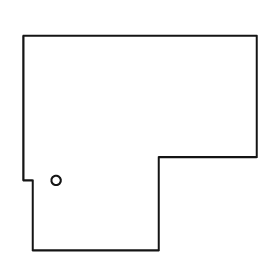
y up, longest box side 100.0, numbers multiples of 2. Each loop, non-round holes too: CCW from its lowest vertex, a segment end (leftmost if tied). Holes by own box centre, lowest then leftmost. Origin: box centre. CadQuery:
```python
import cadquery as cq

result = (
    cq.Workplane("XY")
    .moveTo(-46.0, -46.0)
    .lineTo(8.0, -46.0)
    .lineTo(8.0, -6.0)
    .lineTo(50.0, -6.0)
    .lineTo(50.0, 46.0)
    .lineTo(-50.0, 46.0)
    .lineTo(-50.0, -16.0)
    .lineTo(-46.0, -16.0)
    .close()
    .moveTo(-36.0, -16.0)
    .circle(2.0)
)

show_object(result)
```